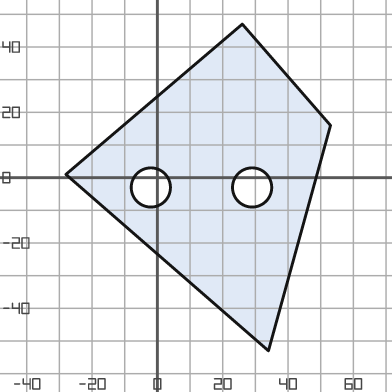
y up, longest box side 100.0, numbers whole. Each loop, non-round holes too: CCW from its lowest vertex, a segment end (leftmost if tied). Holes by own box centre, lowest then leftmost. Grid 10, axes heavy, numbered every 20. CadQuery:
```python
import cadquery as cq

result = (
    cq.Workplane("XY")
    .moveTo(34.0, -53.0)
    .lineTo(53.0, 16.0)
    .lineTo(26.0, 47.0)
    .lineTo(-28.0, 1.0)
    .close()
    .moveTo(-2.0, -3.0)
    .circle(6.0)
    .moveTo(29.0, -3.0)
    .circle(6.0)
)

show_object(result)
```